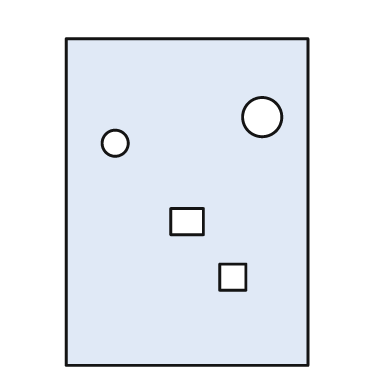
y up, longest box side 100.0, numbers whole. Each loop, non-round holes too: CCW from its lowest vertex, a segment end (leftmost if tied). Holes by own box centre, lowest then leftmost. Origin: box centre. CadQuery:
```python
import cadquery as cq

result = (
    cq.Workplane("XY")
    .moveTo(-37.0, -50.0)
    .lineTo(37.0, -50.0)
    .lineTo(37.0, 50.0)
    .lineTo(-37.0, 50.0)
    .close()
    .moveTo(10.0, -27.0)
    .lineTo(18.0, -27.0)
    .lineTo(18.0, -19.0)
    .lineTo(10.0, -19.0)
    .close()
    .moveTo(-5.0, -10.0)
    .lineTo(5.0, -10.0)
    .lineTo(5.0, -2.0)
    .lineTo(-5.0, -2.0)
    .close()
    .moveTo(-22.0, 18.0)
    .circle(4.0)
    .moveTo(23.0, 26.0)
    .circle(6.0)
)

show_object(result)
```